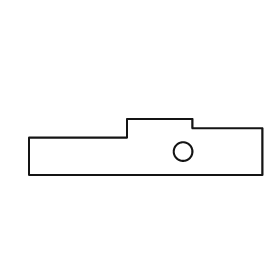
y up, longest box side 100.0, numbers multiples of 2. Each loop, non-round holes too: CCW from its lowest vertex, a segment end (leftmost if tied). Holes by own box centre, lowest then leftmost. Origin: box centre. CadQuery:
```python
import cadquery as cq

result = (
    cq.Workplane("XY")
    .moveTo(-50.0, -12.0)
    .lineTo(50.0, -12.0)
    .lineTo(50.0, 8.0)
    .lineTo(20.0, 8.0)
    .lineTo(20.0, 12.0)
    .lineTo(-8.0, 12.0)
    .lineTo(-8.0, 4.0)
    .lineTo(-50.0, 4.0)
    .close()
    .moveTo(16.0, -2.0)
    .circle(4.0)
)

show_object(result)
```